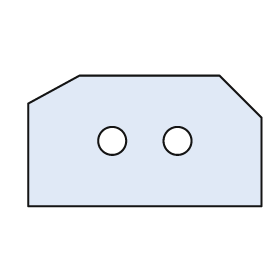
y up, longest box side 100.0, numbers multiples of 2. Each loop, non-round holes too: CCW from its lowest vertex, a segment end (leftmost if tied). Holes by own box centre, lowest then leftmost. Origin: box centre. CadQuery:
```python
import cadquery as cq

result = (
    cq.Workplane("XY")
    .moveTo(-50.0, -28.0)
    .lineTo(50.0, -28.0)
    .lineTo(50.0, 10.0)
    .lineTo(32.0, 28.0)
    .lineTo(-28.0, 28.0)
    .lineTo(-50.0, 16.0)
    .close()
    .moveTo(-14.0, 0.0)
    .circle(6.0)
    .moveTo(14.0, 0.0)
    .circle(6.0)
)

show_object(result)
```